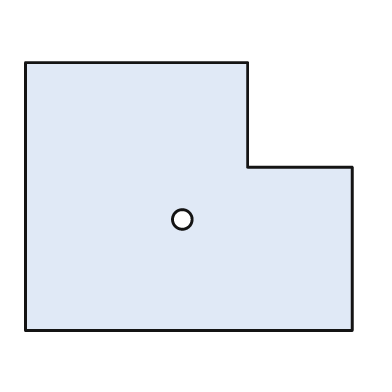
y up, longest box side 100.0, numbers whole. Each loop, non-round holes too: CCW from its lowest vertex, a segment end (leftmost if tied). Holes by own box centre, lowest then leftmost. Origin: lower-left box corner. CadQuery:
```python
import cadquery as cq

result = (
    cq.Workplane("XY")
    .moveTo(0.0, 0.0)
    .lineTo(100.0, 0.0)
    .lineTo(100.0, 50.0)
    .lineTo(68.0, 50.0)
    .lineTo(68.0, 82.0)
    .lineTo(0.0, 82.0)
    .close()
    .moveTo(48.0, 34.0)
    .circle(3.0)
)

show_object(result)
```